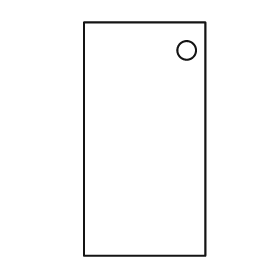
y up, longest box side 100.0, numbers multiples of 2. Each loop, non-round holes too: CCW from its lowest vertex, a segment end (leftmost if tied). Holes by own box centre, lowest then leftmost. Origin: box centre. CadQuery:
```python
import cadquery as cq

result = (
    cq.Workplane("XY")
    .moveTo(-26.0, -50.0)
    .lineTo(26.0, -50.0)
    .lineTo(26.0, 50.0)
    .lineTo(-26.0, 50.0)
    .close()
    .moveTo(18.0, 38.0)
    .circle(4.0)
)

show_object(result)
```